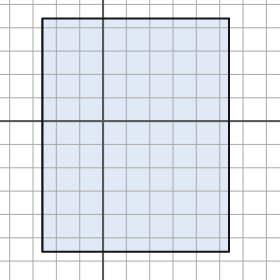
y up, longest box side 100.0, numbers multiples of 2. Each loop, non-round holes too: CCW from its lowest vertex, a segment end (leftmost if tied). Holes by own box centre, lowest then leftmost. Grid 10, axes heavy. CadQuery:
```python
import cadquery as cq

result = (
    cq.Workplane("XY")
    .moveTo(-26.0, -56.0)
    .lineTo(54.0, -56.0)
    .lineTo(54.0, 44.0)
    .lineTo(-26.0, 44.0)
    .close()
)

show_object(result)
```